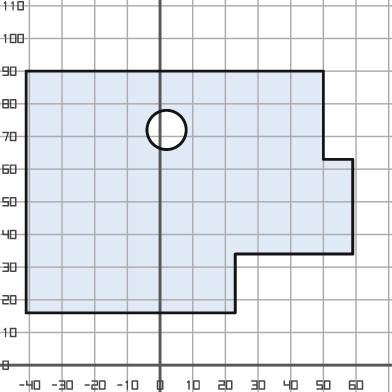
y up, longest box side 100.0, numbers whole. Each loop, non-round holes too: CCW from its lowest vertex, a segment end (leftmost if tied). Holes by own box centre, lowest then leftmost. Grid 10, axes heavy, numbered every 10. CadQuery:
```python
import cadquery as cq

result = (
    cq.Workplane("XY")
    .moveTo(-41.0, 16.0)
    .lineTo(23.0, 16.0)
    .lineTo(23.0, 34.0)
    .lineTo(59.0, 34.0)
    .lineTo(59.0, 63.0)
    .lineTo(50.0, 63.0)
    .lineTo(50.0, 90.0)
    .lineTo(-41.0, 90.0)
    .close()
    .moveTo(2.0, 72.0)
    .circle(6.0)
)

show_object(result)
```